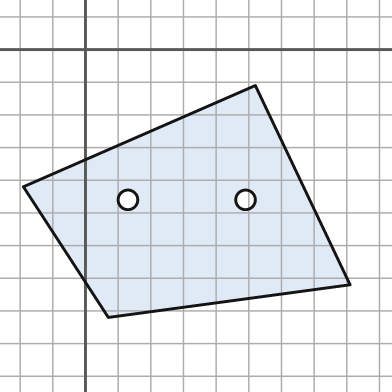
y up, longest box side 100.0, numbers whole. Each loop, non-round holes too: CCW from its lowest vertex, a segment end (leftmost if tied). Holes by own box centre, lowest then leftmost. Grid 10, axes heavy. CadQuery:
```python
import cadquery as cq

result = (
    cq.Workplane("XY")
    .moveTo(7.0, -82.0)
    .lineTo(81.0, -72.0)
    .lineTo(52.0, -11.0)
    .lineTo(-19.0, -42.0)
    .close()
    .moveTo(13.0, -46.0)
    .circle(3.0)
    .moveTo(49.0, -46.0)
    .circle(3.0)
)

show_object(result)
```